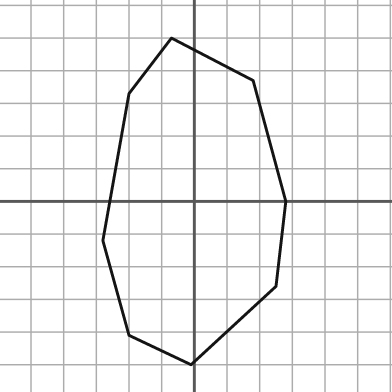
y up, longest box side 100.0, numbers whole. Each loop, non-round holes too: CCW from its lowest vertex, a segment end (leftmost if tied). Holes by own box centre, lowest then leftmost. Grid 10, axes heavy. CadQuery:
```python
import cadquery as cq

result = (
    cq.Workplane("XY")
    .moveTo(-1.0, -50.0)
    .lineTo(25.0, -26.0)
    .lineTo(28.0, 0.0)
    .lineTo(18.0, 37.0)
    .lineTo(-7.0, 50.0)
    .lineTo(-20.0, 33.0)
    .lineTo(-28.0, -12.0)
    .lineTo(-20.0, -41.0)
    .close()
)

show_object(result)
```